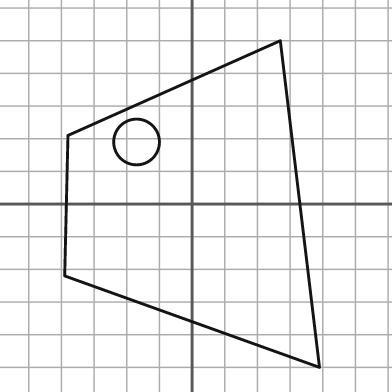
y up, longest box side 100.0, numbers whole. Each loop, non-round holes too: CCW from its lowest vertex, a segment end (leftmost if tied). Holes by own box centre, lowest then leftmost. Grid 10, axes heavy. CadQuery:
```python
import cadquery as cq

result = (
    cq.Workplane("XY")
    .moveTo(39.0, -50.0)
    .lineTo(27.0, 50.0)
    .lineTo(-38.0, 21.0)
    .lineTo(-39.0, -22.0)
    .close()
    .moveTo(-17.0, 19.0)
    .circle(7.0)
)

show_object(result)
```